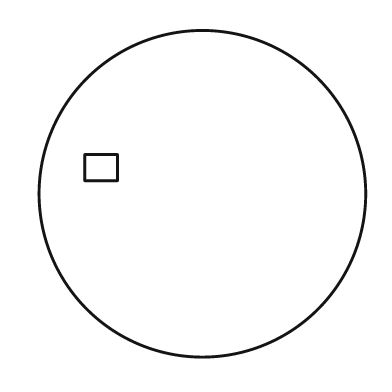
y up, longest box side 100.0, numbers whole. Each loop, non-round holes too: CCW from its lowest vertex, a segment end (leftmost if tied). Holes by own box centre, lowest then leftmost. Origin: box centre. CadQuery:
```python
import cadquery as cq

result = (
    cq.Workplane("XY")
    .moveTo(0.0, 0.0)
    .circle(50.0)
    .moveTo(-36.0, 4.0)
    .lineTo(-26.0, 4.0)
    .lineTo(-26.0, 12.0)
    .lineTo(-36.0, 12.0)
    .close()
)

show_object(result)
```